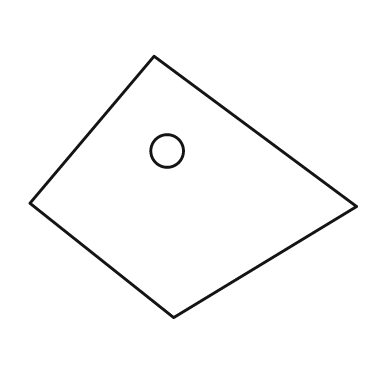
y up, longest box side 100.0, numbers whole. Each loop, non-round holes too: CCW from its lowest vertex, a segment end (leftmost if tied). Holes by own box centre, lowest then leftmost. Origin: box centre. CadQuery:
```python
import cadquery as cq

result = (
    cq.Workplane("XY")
    .moveTo(-6.0, -40.0)
    .lineTo(50.0, -6.0)
    .lineTo(-12.0, 40.0)
    .lineTo(-50.0, -5.0)
    .close()
    .moveTo(-8.0, 11.0)
    .circle(5.0)
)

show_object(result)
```